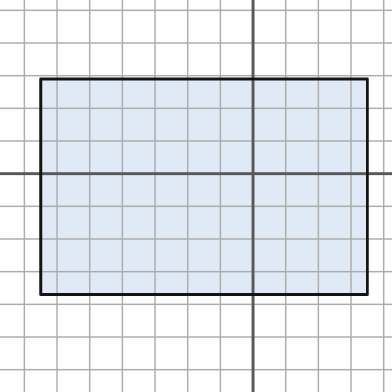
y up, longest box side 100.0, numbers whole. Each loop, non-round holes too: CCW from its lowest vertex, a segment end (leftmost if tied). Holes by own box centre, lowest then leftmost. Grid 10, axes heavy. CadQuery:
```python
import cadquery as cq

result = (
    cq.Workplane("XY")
    .moveTo(-65.0, -37.0)
    .lineTo(35.0, -37.0)
    .lineTo(35.0, 29.0)
    .lineTo(-65.0, 29.0)
    .close()
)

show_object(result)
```